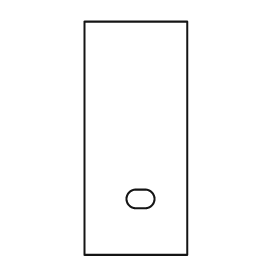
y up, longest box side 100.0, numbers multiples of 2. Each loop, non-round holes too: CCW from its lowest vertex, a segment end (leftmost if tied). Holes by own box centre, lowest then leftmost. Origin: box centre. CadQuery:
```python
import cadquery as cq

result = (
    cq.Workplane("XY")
    .moveTo(-22.0, -50.0)
    .lineTo(22.0, -50.0)
    .lineTo(22.0, 50.0)
    .lineTo(-22.0, 50.0)
    .close()
    .moveTo(0.0, -30.0)
    .lineTo(4.0, -30.0)
    .threePointArc((8.0, -26.0), (4.0, -22.0))
    .lineTo(0.0, -22.0)
    .threePointArc((-4.0, -26.0), (0.0, -30.0))
    .close()
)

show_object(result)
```